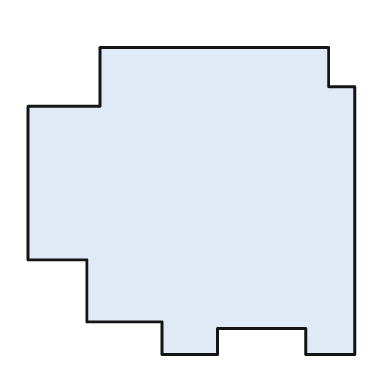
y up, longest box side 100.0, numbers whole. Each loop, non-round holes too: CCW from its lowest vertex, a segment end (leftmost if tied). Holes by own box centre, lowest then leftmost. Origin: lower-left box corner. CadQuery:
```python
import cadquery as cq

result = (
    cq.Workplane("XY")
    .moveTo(41.0, 0.0)
    .lineTo(58.0, 0.0)
    .lineTo(58.0, 8.0)
    .lineTo(85.0, 8.0)
    .lineTo(85.0, 0.0)
    .lineTo(100.0, 0.0)
    .lineTo(100.0, 82.0)
    .lineTo(92.0, 82.0)
    .lineTo(92.0, 94.0)
    .lineTo(22.0, 94.0)
    .lineTo(22.0, 76.0)
    .lineTo(0.0, 76.0)
    .lineTo(0.0, 29.0)
    .lineTo(18.0, 29.0)
    .lineTo(18.0, 10.0)
    .lineTo(41.0, 10.0)
    .close()
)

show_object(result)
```